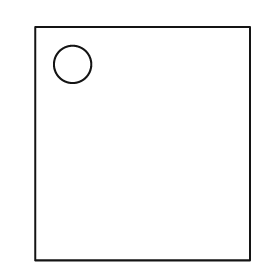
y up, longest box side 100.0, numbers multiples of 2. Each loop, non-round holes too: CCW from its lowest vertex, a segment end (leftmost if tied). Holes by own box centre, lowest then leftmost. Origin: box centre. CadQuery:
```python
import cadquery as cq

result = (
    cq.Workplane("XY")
    .moveTo(-46.0, -50.0)
    .lineTo(46.0, -50.0)
    .lineTo(46.0, 50.0)
    .lineTo(-46.0, 50.0)
    .close()
    .moveTo(-30.0, 34.0)
    .circle(8.0)
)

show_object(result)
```